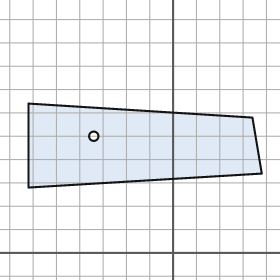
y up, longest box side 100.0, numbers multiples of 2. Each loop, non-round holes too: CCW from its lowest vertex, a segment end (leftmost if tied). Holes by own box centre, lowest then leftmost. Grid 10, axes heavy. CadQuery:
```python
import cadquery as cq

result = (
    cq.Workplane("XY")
    .moveTo(-62.0, 28.0)
    .lineTo(38.0, 34.0)
    .lineTo(34.0, 58.0)
    .lineTo(-62.0, 64.0)
    .close()
    .moveTo(-34.0, 50.0)
    .circle(2.0)
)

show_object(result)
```